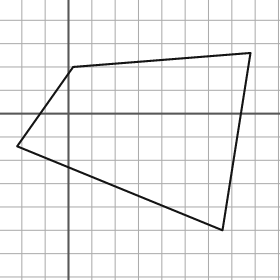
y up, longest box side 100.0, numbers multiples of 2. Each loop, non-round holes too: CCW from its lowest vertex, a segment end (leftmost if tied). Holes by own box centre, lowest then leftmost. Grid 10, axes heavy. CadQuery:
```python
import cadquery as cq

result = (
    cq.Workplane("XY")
    .moveTo(66.0, -50.0)
    .lineTo(78.0, 26.0)
    .lineTo(2.0, 20.0)
    .lineTo(-22.0, -14.0)
    .close()
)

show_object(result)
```